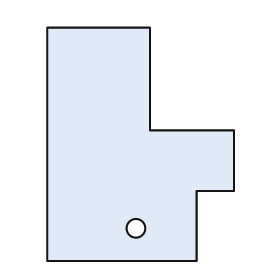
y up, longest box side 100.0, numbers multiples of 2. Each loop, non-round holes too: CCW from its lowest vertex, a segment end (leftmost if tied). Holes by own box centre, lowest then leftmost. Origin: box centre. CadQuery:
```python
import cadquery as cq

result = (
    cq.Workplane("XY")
    .moveTo(-40.0, -50.0)
    .lineTo(24.0, -50.0)
    .lineTo(24.0, -20.0)
    .lineTo(40.0, -20.0)
    .lineTo(40.0, 6.0)
    .lineTo(4.0, 6.0)
    .lineTo(4.0, 50.0)
    .lineTo(-40.0, 50.0)
    .close()
    .moveTo(-2.0, -36.0)
    .circle(4.0)
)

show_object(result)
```